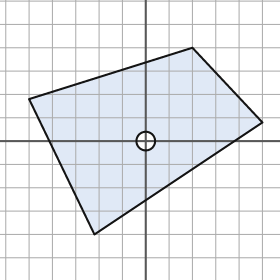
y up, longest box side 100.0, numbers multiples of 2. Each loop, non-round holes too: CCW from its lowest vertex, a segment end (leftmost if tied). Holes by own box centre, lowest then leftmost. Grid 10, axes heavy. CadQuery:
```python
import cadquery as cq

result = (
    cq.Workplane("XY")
    .moveTo(-22.0, -40.0)
    .lineTo(50.0, 8.0)
    .lineTo(20.0, 40.0)
    .lineTo(-50.0, 18.0)
    .close()
    .moveTo(0.0, 0.0)
    .circle(4.0)
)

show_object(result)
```